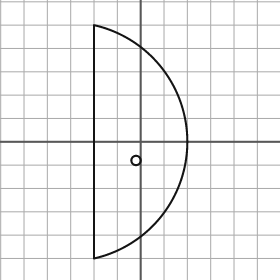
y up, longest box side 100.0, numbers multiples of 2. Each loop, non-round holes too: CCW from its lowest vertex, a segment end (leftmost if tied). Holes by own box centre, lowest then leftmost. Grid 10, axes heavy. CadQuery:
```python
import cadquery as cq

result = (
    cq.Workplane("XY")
    .moveTo(-20.0, -50.0)
    .threePointArc((20.0, 0.0), (-20.0, 50.0))
    .close()
    .moveTo(-2.0, -8.0)
    .circle(2.0)
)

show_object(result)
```